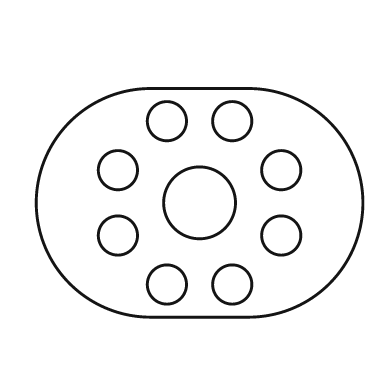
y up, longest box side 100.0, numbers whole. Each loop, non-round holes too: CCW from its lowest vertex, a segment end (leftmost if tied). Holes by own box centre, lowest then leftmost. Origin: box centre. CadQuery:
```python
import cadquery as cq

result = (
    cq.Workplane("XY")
    .moveTo(-15.0, -35.0)
    .lineTo(15.0, -35.0)
    .threePointArc((50.0, 0.0), (15.0, 35.0))
    .lineTo(-15.0, 35.0)
    .threePointArc((-50.0, 0.0), (-15.0, -35.0))
    .close()
    .moveTo(-10.0, -25.0)
    .circle(6.0)
    .moveTo(10.0, -25.0)
    .circle(6.0)
    .moveTo(-25.0, -10.0)
    .circle(6.0)
    .moveTo(25.0, -10.0)
    .circle(6.0)
    .moveTo(0.0, 0.0)
    .circle(11.0)
    .moveTo(-25.0, 10.0)
    .circle(6.0)
    .moveTo(25.0, 10.0)
    .circle(6.0)
    .moveTo(-10.0, 25.0)
    .circle(6.0)
    .moveTo(10.0, 25.0)
    .circle(6.0)
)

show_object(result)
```